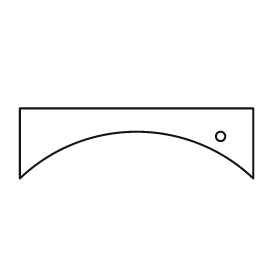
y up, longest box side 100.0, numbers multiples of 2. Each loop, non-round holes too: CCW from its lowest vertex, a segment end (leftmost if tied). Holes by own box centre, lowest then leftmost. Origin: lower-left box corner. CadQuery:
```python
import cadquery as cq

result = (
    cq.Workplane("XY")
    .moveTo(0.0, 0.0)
    .threePointArc((50.0, 20.0), (100.0, 0.0))
    .lineTo(100.0, 30.0)
    .lineTo(0.0, 30.0)
    .close()
    .moveTo(86.0, 18.0)
    .circle(2.0)
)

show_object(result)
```